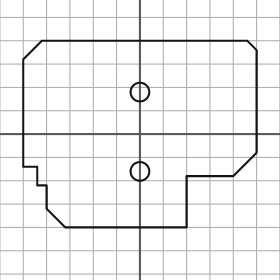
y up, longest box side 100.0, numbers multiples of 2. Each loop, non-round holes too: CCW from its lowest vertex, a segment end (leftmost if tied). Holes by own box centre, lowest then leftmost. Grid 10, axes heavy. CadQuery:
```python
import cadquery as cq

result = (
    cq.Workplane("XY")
    .moveTo(-32.0, -40.0)
    .lineTo(20.0, -40.0)
    .lineTo(20.0, -18.0)
    .lineTo(40.0, -18.0)
    .lineTo(50.0, -8.0)
    .lineTo(50.0, 36.0)
    .lineTo(46.0, 40.0)
    .lineTo(-42.0, 40.0)
    .lineTo(-50.0, 32.0)
    .lineTo(-50.0, -14.0)
    .lineTo(-44.0, -14.0)
    .lineTo(-44.0, -22.0)
    .lineTo(-40.0, -22.0)
    .lineTo(-40.0, -32.0)
    .close()
    .moveTo(0.0, -16.0)
    .circle(4.0)
    .moveTo(0.0, 18.0)
    .circle(4.0)
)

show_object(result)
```